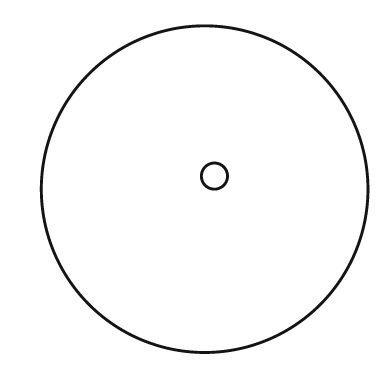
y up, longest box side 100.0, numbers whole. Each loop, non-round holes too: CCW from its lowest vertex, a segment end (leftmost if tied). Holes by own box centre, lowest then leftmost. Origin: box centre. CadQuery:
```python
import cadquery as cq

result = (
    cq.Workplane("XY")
    .moveTo(0.0, 0.0)
    .circle(50.0)
    .moveTo(3.0, 4.0)
    .circle(4.0)
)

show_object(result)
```